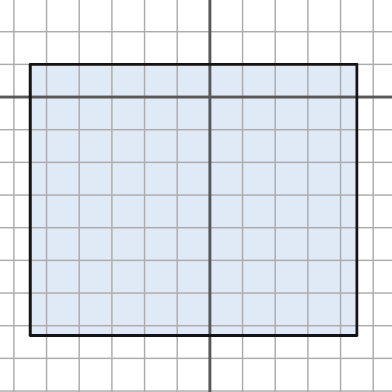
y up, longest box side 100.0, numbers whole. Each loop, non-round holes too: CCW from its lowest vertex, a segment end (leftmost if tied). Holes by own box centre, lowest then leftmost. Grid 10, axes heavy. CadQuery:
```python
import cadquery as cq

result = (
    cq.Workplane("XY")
    .moveTo(-55.0, -73.0)
    .lineTo(45.0, -73.0)
    .lineTo(45.0, 10.0)
    .lineTo(-55.0, 10.0)
    .close()
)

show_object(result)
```